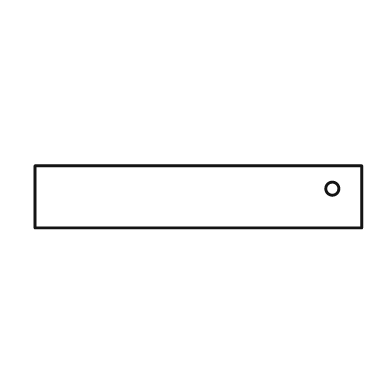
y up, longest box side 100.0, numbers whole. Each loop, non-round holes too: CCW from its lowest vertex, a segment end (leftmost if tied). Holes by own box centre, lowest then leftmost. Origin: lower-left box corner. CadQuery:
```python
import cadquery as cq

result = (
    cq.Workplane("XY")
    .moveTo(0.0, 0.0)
    .lineTo(100.0, 0.0)
    .lineTo(100.0, 19.0)
    .lineTo(0.0, 19.0)
    .close()
    .moveTo(91.0, 12.0)
    .circle(2.0)
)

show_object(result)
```